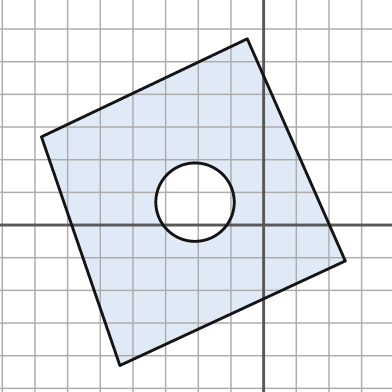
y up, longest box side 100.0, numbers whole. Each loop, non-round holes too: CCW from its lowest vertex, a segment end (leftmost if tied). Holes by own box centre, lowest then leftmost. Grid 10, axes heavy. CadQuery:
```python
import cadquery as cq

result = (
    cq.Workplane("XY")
    .moveTo(-44.0, -43.0)
    .lineTo(25.0, -11.0)
    .lineTo(-5.0, 57.0)
    .lineTo(-68.0, 27.0)
    .close()
    .moveTo(-21.0, 7.0)
    .circle(12.0)
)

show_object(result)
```